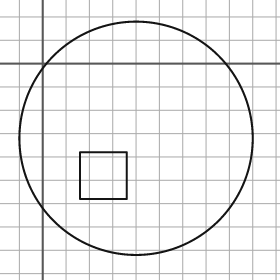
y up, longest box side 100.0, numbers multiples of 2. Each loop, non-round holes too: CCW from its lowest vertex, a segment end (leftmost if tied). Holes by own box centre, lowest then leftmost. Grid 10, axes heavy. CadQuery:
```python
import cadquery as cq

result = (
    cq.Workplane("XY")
    .moveTo(40.0, -32.0)
    .circle(50.0)
    .moveTo(16.0, -58.0)
    .lineTo(36.0, -58.0)
    .lineTo(36.0, -38.0)
    .lineTo(16.0, -38.0)
    .close()
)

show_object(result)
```